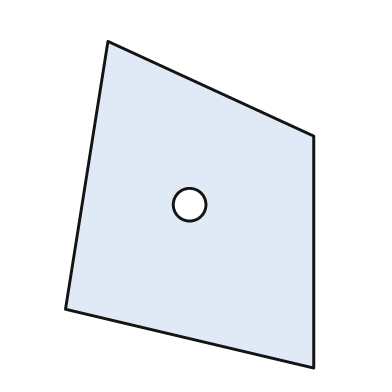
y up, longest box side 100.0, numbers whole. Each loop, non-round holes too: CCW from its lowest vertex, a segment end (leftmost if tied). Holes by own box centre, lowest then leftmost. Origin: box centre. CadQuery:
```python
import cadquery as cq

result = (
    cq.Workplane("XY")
    .moveTo(38.0, -50.0)
    .lineTo(38.0, 21.0)
    .lineTo(-25.0, 50.0)
    .lineTo(-38.0, -32.0)
    .close()
    .moveTo(0.0, 0.0)
    .circle(5.0)
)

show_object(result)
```